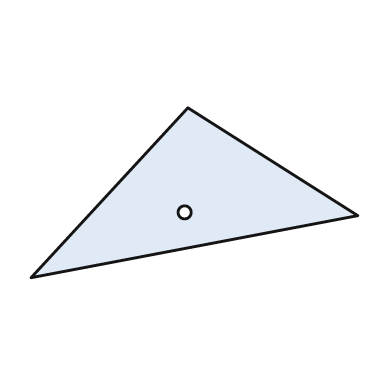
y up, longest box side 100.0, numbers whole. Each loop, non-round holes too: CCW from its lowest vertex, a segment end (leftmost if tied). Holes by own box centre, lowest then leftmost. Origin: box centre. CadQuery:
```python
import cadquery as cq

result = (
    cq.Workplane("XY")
    .moveTo(-50.0, -26.0)
    .lineTo(50.0, -7.0)
    .lineTo(-2.0, 26.0)
    .close()
    .moveTo(-3.0, -6.0)
    .circle(2.0)
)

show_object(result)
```